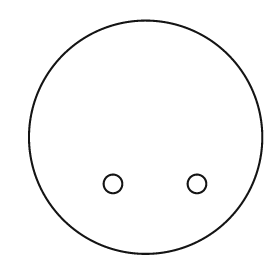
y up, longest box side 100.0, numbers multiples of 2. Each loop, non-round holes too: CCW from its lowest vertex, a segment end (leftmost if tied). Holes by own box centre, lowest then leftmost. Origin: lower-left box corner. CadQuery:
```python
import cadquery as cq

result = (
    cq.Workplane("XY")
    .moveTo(50.0, 50.0)
    .circle(50.0)
    .moveTo(36.0, 30.0)
    .circle(4.0)
    .moveTo(72.0, 30.0)
    .circle(4.0)
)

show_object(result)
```